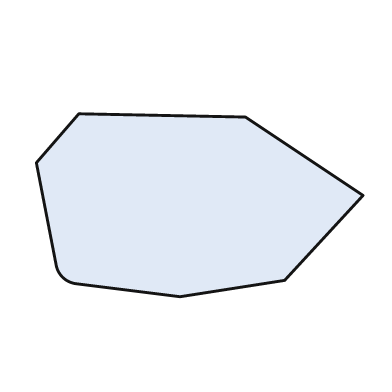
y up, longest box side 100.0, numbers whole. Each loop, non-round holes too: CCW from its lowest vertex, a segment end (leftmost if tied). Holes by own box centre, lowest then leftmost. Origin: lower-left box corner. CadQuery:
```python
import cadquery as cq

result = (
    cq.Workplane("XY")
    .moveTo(44.0, 0.0)
    .lineTo(76.0, 5.0)
    .lineTo(100.0, 31.0)
    .lineTo(64.0, 55.0)
    .lineTo(13.0, 56.0)
    .lineTo(0.0, 41.0)
    .lineTo(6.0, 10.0)
    .threePointArc((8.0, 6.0), (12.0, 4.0))
    .close()
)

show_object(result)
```